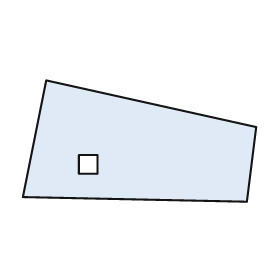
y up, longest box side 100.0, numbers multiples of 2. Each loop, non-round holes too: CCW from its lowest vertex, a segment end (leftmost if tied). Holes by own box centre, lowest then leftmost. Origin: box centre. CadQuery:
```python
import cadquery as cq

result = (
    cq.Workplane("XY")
    .moveTo(46.0, -26.0)
    .lineTo(50.0, 6.0)
    .lineTo(-40.0, 26.0)
    .lineTo(-50.0, -24.0)
    .close()
    .moveTo(-26.0, -14.0)
    .lineTo(-18.0, -14.0)
    .lineTo(-18.0, -6.0)
    .lineTo(-26.0, -6.0)
    .close()
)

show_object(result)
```